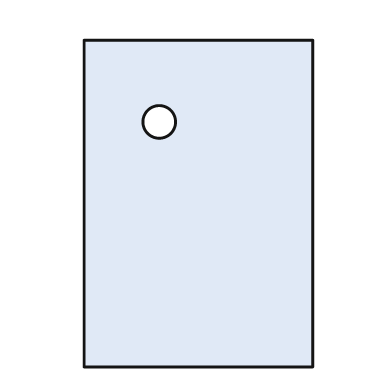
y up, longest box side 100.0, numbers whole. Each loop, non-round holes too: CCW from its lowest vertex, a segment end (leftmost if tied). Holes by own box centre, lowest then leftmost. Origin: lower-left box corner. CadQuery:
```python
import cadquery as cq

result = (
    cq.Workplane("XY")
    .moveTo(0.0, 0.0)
    .lineTo(70.0, 0.0)
    .lineTo(70.0, 100.0)
    .lineTo(0.0, 100.0)
    .close()
    .moveTo(23.0, 75.0)
    .circle(5.0)
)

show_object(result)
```